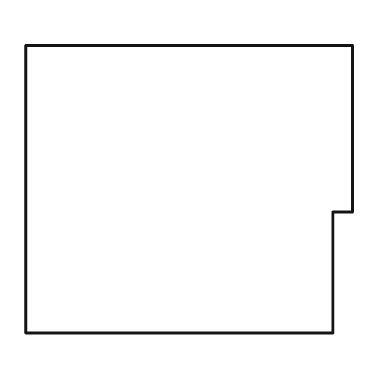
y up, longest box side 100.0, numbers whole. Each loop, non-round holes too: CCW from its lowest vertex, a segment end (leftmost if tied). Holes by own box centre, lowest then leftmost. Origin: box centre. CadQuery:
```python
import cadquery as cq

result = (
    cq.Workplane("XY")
    .moveTo(-50.0, -44.0)
    .lineTo(44.0, -44.0)
    .lineTo(44.0, -7.0)
    .lineTo(50.0, -7.0)
    .lineTo(50.0, 44.0)
    .lineTo(-50.0, 44.0)
    .close()
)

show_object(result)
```